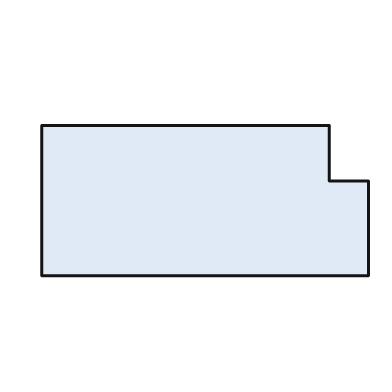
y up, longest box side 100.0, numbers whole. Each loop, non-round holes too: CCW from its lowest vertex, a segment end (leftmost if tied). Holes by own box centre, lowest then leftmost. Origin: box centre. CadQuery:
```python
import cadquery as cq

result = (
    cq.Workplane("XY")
    .moveTo(-50.0, -23.0)
    .lineTo(50.0, -23.0)
    .lineTo(50.0, 6.0)
    .lineTo(38.0, 6.0)
    .lineTo(38.0, 23.0)
    .lineTo(-50.0, 23.0)
    .close()
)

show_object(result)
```